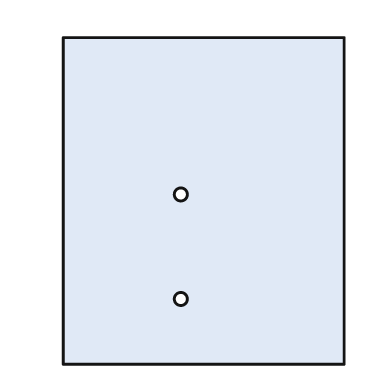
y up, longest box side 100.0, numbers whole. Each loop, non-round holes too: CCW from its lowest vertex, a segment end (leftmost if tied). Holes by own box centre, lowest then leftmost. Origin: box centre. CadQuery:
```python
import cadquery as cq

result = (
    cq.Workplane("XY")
    .moveTo(-43.0, -50.0)
    .lineTo(43.0, -50.0)
    .lineTo(43.0, 50.0)
    .lineTo(-43.0, 50.0)
    .close()
    .moveTo(-7.0, -30.0)
    .circle(2.0)
    .moveTo(-7.0, 2.0)
    .circle(2.0)
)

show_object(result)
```